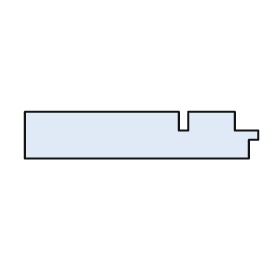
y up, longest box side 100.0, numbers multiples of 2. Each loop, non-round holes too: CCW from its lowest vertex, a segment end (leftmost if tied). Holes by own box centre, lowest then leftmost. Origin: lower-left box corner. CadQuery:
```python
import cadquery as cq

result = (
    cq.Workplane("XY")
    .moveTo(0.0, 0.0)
    .lineTo(96.0, 0.0)
    .lineTo(96.0, 8.0)
    .lineTo(100.0, 8.0)
    .lineTo(100.0, 12.0)
    .lineTo(90.0, 12.0)
    .lineTo(90.0, 20.0)
    .lineTo(70.0, 20.0)
    .lineTo(70.0, 12.0)
    .lineTo(66.0, 12.0)
    .lineTo(66.0, 20.0)
    .lineTo(0.0, 20.0)
    .close()
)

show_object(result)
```